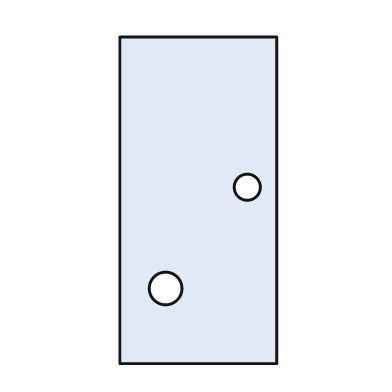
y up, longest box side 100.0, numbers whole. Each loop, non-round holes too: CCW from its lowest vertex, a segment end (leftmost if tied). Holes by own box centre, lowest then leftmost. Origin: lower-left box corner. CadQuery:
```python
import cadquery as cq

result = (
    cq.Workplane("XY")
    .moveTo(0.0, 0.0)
    .lineTo(48.0, 0.0)
    .lineTo(48.0, 100.0)
    .lineTo(0.0, 100.0)
    .close()
    .moveTo(14.0, 23.0)
    .circle(5.0)
    .moveTo(39.0, 54.0)
    .circle(4.0)
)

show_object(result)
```